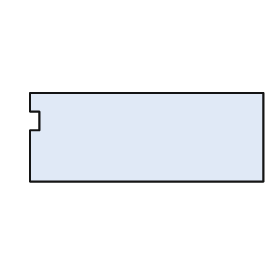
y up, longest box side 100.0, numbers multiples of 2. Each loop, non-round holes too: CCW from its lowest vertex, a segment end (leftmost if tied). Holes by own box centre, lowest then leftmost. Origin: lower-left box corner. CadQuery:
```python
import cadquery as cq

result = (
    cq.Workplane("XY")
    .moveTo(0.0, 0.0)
    .lineTo(100.0, 0.0)
    .lineTo(100.0, 38.0)
    .lineTo(0.0, 38.0)
    .lineTo(0.0, 30.0)
    .lineTo(4.0, 30.0)
    .lineTo(4.0, 22.0)
    .lineTo(0.0, 22.0)
    .close()
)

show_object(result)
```